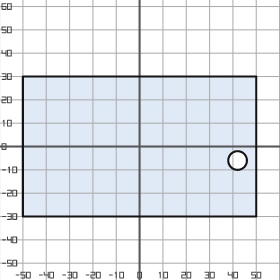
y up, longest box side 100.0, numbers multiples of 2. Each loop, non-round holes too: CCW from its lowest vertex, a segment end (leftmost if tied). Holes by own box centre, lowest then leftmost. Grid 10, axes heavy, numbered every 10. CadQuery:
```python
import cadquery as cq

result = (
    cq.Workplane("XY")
    .moveTo(-50.0, -30.0)
    .lineTo(50.0, -30.0)
    .lineTo(50.0, 30.0)
    .lineTo(-50.0, 30.0)
    .close()
    .moveTo(42.0, -6.0)
    .circle(4.0)
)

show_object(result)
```